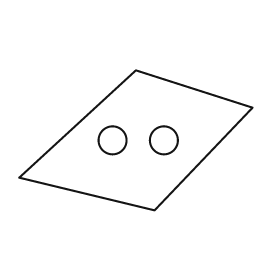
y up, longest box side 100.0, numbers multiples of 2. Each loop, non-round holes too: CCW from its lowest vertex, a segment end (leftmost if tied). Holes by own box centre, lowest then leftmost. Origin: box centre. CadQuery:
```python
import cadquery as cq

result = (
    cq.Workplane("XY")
    .moveTo(8.0, -30.0)
    .lineTo(50.0, 14.0)
    .lineTo(0.0, 30.0)
    .lineTo(-50.0, -16.0)
    .close()
    .moveTo(-10.0, 0.0)
    .circle(6.0)
    .moveTo(12.0, 0.0)
    .circle(6.0)
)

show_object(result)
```